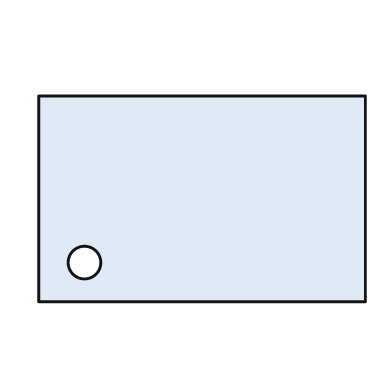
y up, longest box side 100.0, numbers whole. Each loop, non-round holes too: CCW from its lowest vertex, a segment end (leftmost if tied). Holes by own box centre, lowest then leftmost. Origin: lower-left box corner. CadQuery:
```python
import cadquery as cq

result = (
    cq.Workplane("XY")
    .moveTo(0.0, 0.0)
    .lineTo(100.0, 0.0)
    .lineTo(100.0, 63.0)
    .lineTo(0.0, 63.0)
    .close()
    .moveTo(14.0, 12.0)
    .circle(5.0)
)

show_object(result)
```